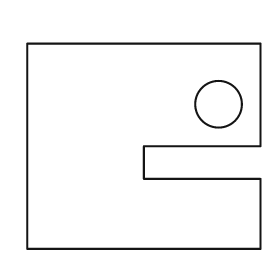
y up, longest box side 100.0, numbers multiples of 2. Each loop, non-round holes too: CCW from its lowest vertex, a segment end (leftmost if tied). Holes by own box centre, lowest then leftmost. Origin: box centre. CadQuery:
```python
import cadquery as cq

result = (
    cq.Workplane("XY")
    .moveTo(-50.0, -44.0)
    .lineTo(50.0, -44.0)
    .lineTo(50.0, -14.0)
    .lineTo(0.0, -14.0)
    .lineTo(0.0, 0.0)
    .lineTo(50.0, 0.0)
    .lineTo(50.0, 44.0)
    .lineTo(-50.0, 44.0)
    .close()
    .moveTo(32.0, 18.0)
    .circle(10.0)
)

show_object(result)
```